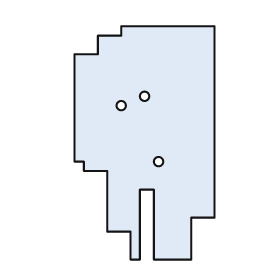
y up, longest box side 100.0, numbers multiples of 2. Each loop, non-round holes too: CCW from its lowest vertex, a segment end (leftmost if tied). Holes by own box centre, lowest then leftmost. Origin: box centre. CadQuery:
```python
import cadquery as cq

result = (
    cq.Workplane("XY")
    .moveTo(-6.0, -50.0)
    .lineTo(-2.0, -50.0)
    .lineTo(-2.0, -20.0)
    .lineTo(4.0, -20.0)
    .lineTo(4.0, -50.0)
    .lineTo(20.0, -50.0)
    .lineTo(20.0, -32.0)
    .lineTo(30.0, -32.0)
    .lineTo(30.0, 50.0)
    .lineTo(-10.0, 50.0)
    .lineTo(-10.0, 46.0)
    .lineTo(-20.0, 46.0)
    .lineTo(-20.0, 38.0)
    .lineTo(-30.0, 38.0)
    .lineTo(-30.0, -8.0)
    .lineTo(-26.0, -8.0)
    .lineTo(-26.0, -12.0)
    .lineTo(-16.0, -12.0)
    .lineTo(-16.0, -38.0)
    .lineTo(-6.0, -38.0)
    .close()
    .moveTo(6.0, -8.0)
    .circle(2.0)
    .moveTo(-10.0, 16.0)
    .circle(2.0)
    .moveTo(0.0, 20.0)
    .circle(2.0)
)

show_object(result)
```